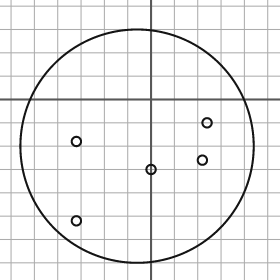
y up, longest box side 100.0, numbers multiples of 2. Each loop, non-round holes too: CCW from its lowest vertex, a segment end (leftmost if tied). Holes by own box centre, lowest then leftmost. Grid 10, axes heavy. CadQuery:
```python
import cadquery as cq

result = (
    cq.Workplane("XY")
    .moveTo(-6.0, -20.0)
    .circle(50.0)
    .moveTo(-32.0, -52.0)
    .circle(2.0)
    .moveTo(0.0, -30.0)
    .circle(2.0)
    .moveTo(22.0, -26.0)
    .circle(2.0)
    .moveTo(-32.0, -18.0)
    .circle(2.0)
    .moveTo(24.0, -10.0)
    .circle(2.0)
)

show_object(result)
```